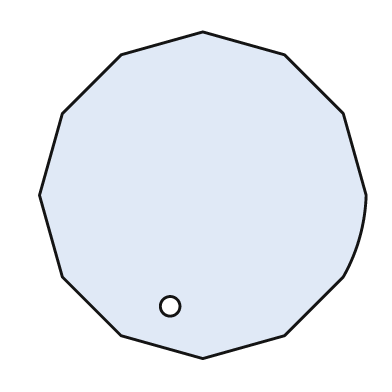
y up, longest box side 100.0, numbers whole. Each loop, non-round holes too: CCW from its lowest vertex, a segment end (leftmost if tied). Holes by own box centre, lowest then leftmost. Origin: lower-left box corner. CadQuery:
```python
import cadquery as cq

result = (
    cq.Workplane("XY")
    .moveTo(50.0, 0.0)
    .lineTo(75.0, 7.0)
    .lineTo(93.0, 25.0)
    .threePointArc((98.0, 37.0), (100.0, 50.0))
    .lineTo(93.0, 75.0)
    .lineTo(75.0, 93.0)
    .lineTo(50.0, 100.0)
    .lineTo(25.0, 93.0)
    .lineTo(7.0, 75.0)
    .lineTo(0.0, 50.0)
    .lineTo(7.0, 25.0)
    .lineTo(25.0, 7.0)
    .close()
    .moveTo(40.0, 16.0)
    .circle(3.0)
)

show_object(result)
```